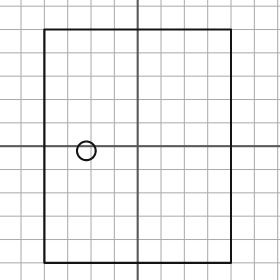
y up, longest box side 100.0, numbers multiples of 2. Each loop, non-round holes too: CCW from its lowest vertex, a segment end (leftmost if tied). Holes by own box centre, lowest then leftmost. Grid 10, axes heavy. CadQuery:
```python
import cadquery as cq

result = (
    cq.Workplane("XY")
    .moveTo(-40.0, -50.0)
    .lineTo(40.0, -50.0)
    .lineTo(40.0, 50.0)
    .lineTo(-40.0, 50.0)
    .close()
    .moveTo(-22.0, -2.0)
    .circle(4.0)
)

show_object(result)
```